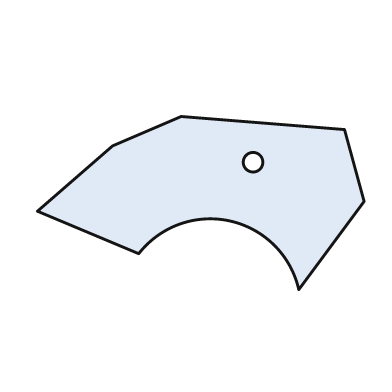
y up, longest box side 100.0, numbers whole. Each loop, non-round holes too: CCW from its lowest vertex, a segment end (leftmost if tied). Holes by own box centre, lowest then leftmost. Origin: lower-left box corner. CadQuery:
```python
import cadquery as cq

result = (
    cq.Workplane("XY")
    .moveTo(80.0, 0.0)
    .lineTo(100.0, 27.0)
    .lineTo(94.0, 49.0)
    .lineTo(44.0, 53.0)
    .lineTo(23.0, 44.0)
    .lineTo(0.0, 24.0)
    .lineTo(31.0, 11.0)
    .threePointArc((59.0, 21.0), (80.0, 0.0))
    .close()
    .moveTo(66.0, 39.0)
    .circle(3.0)
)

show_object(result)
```